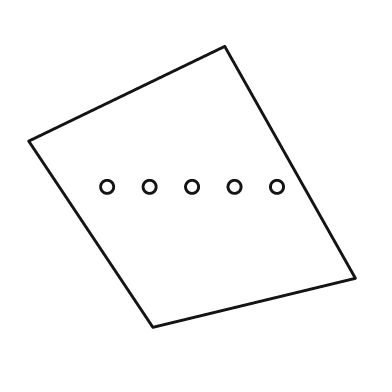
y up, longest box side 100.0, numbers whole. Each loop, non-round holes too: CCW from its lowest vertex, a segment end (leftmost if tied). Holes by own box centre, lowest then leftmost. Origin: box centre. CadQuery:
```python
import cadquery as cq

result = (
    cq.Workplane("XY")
    .moveTo(-12.0, -43.0)
    .lineTo(50.0, -28.0)
    .lineTo(10.0, 43.0)
    .lineTo(-50.0, 14.0)
    .close()
    .moveTo(-26.0, 0.0)
    .circle(2.0)
    .moveTo(-13.0, 0.0)
    .circle(2.0)
    .moveTo(0.0, 0.0)
    .circle(2.0)
    .moveTo(13.0, 0.0)
    .circle(2.0)
    .moveTo(26.0, 0.0)
    .circle(2.0)
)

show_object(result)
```